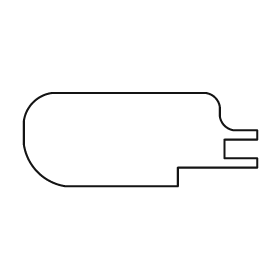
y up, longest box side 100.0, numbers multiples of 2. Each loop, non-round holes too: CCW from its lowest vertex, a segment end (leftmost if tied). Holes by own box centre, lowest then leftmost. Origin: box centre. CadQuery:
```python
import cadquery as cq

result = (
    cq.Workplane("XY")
    .moveTo(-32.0, -20.0)
    .lineTo(16.0, -20.0)
    .lineTo(16.0, -12.0)
    .lineTo(50.0, -12.0)
    .lineTo(50.0, -8.0)
    .lineTo(36.0, -8.0)
    .lineTo(36.0, 0.0)
    .lineTo(50.0, 0.0)
    .lineTo(50.0, 4.0)
    .lineTo(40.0, 4.0)
    .threePointArc((36.0, 6.0), (34.0, 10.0))
    .lineTo(34.0, 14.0)
    .threePointArc((32.0, 18.0), (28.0, 20.0))
    .lineTo(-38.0, 20.0)
    .threePointArc((-46.0, 16.0), (-50.0, 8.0))
    .lineTo(-50.0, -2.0)
    .threePointArc((-44.0, -14.0), (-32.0, -20.0))
    .close()
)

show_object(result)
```